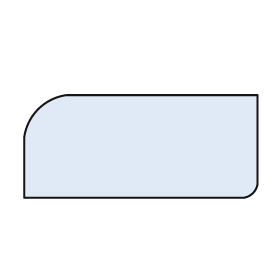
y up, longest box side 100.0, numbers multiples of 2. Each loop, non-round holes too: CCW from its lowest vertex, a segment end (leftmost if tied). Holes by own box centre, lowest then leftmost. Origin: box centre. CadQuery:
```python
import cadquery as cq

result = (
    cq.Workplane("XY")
    .moveTo(-50.0, -22.0)
    .lineTo(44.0, -22.0)
    .threePointArc((48.0, -20.0), (50.0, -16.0))
    .lineTo(50.0, 22.0)
    .lineTo(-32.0, 22.0)
    .threePointArc((-44.0, 16.0), (-50.0, 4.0))
    .close()
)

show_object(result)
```